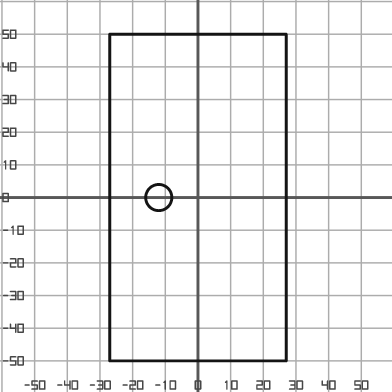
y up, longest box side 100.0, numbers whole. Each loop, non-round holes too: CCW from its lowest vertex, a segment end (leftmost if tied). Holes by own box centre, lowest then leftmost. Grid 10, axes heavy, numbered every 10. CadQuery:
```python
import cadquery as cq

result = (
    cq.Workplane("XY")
    .moveTo(-27.0, -50.0)
    .lineTo(27.0, -50.0)
    .lineTo(27.0, 50.0)
    .lineTo(-27.0, 50.0)
    .close()
    .moveTo(-12.0, 0.0)
    .circle(4.0)
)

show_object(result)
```